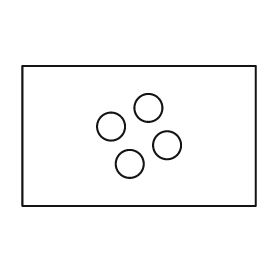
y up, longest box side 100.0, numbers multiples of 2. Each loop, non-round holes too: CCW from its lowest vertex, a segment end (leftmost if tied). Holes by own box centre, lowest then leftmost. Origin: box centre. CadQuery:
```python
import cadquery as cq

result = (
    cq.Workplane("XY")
    .moveTo(-50.0, -30.0)
    .lineTo(50.0, -30.0)
    .lineTo(50.0, 30.0)
    .lineTo(-50.0, 30.0)
    .close()
    .moveTo(-4.0, -12.0)
    .circle(6.0)
    .moveTo(12.0, -4.0)
    .circle(6.0)
    .moveTo(-12.0, 4.0)
    .circle(6.0)
    .moveTo(4.0, 12.0)
    .circle(6.0)
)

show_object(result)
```